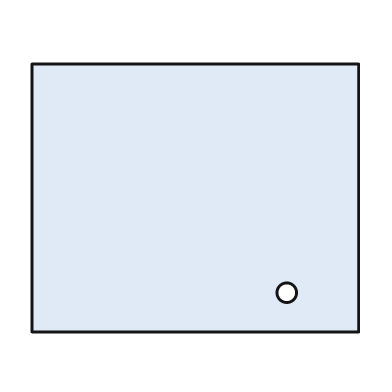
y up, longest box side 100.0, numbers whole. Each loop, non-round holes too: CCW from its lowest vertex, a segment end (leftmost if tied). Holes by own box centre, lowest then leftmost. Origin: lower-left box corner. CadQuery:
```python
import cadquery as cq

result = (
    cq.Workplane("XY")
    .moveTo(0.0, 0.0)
    .lineTo(100.0, 0.0)
    .lineTo(100.0, 82.0)
    .lineTo(0.0, 82.0)
    .close()
    .moveTo(78.0, 12.0)
    .circle(3.0)
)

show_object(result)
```